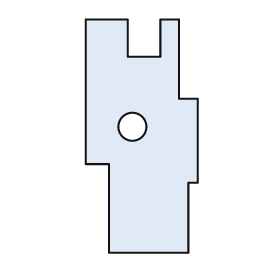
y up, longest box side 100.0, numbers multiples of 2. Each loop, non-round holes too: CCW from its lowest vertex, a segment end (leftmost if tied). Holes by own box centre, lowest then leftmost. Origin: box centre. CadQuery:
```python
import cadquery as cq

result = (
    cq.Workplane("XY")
    .moveTo(-14.0, -50.0)
    .lineTo(20.0, -50.0)
    .lineTo(20.0, -20.0)
    .lineTo(24.0, -20.0)
    .lineTo(24.0, 16.0)
    .lineTo(16.0, 16.0)
    .lineTo(16.0, 50.0)
    .lineTo(8.0, 50.0)
    .lineTo(8.0, 34.0)
    .lineTo(-6.0, 34.0)
    .lineTo(-6.0, 50.0)
    .lineTo(-24.0, 50.0)
    .lineTo(-24.0, -12.0)
    .lineTo(-14.0, -12.0)
    .close()
    .moveTo(-4.0, 4.0)
    .circle(6.0)
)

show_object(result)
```